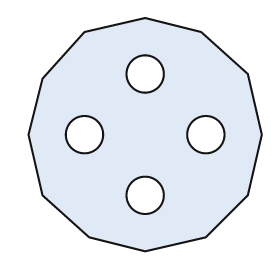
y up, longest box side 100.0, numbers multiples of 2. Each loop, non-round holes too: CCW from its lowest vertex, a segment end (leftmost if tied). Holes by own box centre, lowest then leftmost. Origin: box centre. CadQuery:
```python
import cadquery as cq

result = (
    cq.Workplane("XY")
    .moveTo(0.0, -50.0)
    .lineTo(26.0, -44.0)
    .lineTo(44.0, -26.0)
    .lineTo(50.0, 0.0)
    .lineTo(44.0, 26.0)
    .lineTo(24.0, 44.0)
    .lineTo(0.0, 50.0)
    .lineTo(-26.0, 44.0)
    .lineTo(-44.0, 24.0)
    .lineTo(-50.0, 0.0)
    .lineTo(-44.0, -26.0)
    .lineTo(-24.0, -44.0)
    .close()
    .moveTo(0.0, -26.0)
    .circle(8.0)
    .moveTo(-26.0, 0.0)
    .circle(8.0)
    .moveTo(26.0, 0.0)
    .circle(8.0)
    .moveTo(0.0, 26.0)
    .circle(8.0)
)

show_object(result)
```